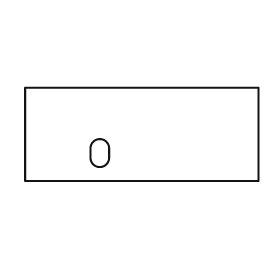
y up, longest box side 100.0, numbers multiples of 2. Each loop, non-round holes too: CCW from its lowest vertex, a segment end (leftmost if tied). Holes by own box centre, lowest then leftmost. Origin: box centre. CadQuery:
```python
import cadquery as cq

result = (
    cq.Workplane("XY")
    .moveTo(-50.0, -20.0)
    .lineTo(50.0, -20.0)
    .lineTo(50.0, 20.0)
    .lineTo(-50.0, 20.0)
    .close()
    .moveTo(-22.0, -10.0)
    .threePointArc((-18.0, -14.0), (-14.0, -10.0))
    .lineTo(-14.0, -6.0)
    .threePointArc((-18.0, -2.0), (-22.0, -6.0))
    .close()
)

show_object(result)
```